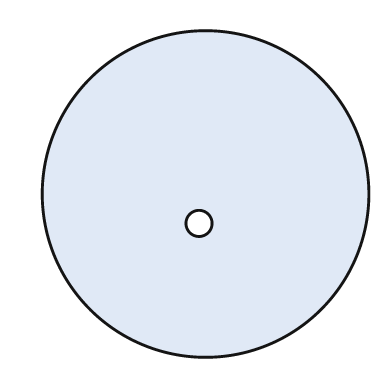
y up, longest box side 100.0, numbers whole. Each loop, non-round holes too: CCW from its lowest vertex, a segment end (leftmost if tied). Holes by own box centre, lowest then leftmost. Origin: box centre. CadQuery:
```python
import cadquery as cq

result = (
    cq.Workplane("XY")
    .moveTo(0.0, 0.0)
    .circle(50.0)
    .moveTo(-2.0, -9.0)
    .circle(4.0)
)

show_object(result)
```